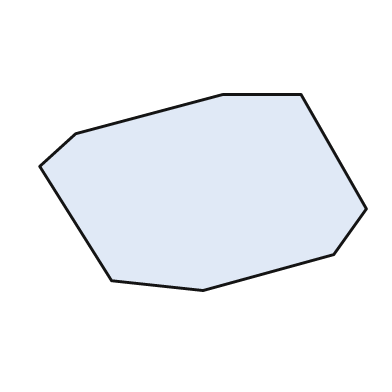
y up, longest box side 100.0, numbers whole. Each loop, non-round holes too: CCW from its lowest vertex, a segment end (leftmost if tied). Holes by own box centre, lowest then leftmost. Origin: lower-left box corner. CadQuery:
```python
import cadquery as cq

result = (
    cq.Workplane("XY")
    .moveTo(50.0, 0.0)
    .lineTo(90.0, 11.0)
    .lineTo(100.0, 25.0)
    .lineTo(80.0, 60.0)
    .lineTo(56.0, 60.0)
    .lineTo(11.0, 48.0)
    .lineTo(0.0, 38.0)
    .lineTo(22.0, 3.0)
    .close()
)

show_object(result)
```